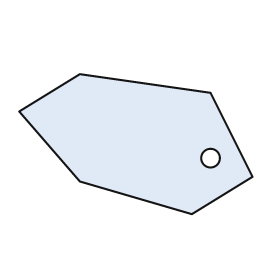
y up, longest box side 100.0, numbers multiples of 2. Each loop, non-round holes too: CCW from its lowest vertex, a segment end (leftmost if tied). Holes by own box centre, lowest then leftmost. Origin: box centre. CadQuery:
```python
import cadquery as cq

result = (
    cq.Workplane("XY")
    .moveTo(24.0, -30.0)
    .lineTo(50.0, -14.0)
    .lineTo(32.0, 22.0)
    .lineTo(-24.0, 30.0)
    .lineTo(-50.0, 14.0)
    .lineTo(-24.0, -16.0)
    .close()
    .moveTo(32.0, -6.0)
    .circle(4.0)
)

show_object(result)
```